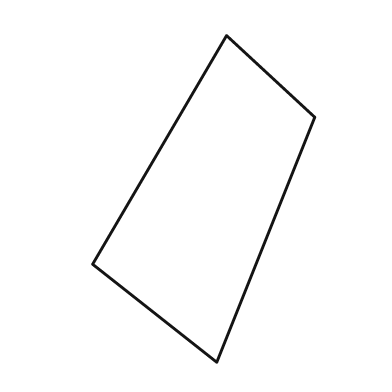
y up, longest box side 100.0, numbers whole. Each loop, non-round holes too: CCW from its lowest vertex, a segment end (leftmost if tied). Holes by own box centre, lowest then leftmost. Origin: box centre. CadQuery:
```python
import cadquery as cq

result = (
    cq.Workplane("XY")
    .moveTo(4.0, -50.0)
    .lineTo(34.0, 25.0)
    .lineTo(7.0, 50.0)
    .lineTo(-34.0, -20.0)
    .close()
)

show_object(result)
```